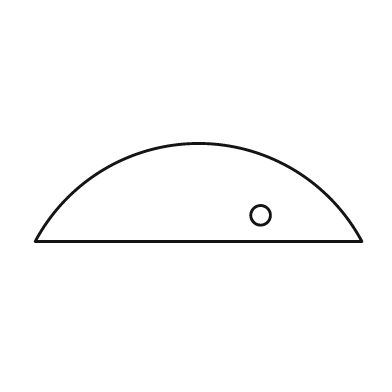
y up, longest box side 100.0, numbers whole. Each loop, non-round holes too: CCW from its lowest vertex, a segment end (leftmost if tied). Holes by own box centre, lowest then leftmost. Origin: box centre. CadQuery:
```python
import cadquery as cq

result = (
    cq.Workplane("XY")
    .moveTo(-50.0, -15.0)
    .lineTo(50.0, -15.0)
    .threePointArc((0.0, 15.0), (-50.0, -15.0))
    .close()
    .moveTo(19.0, -7.0)
    .circle(3.0)
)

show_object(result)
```